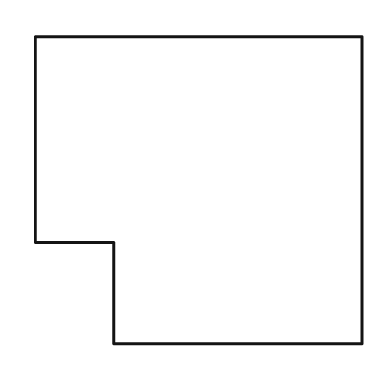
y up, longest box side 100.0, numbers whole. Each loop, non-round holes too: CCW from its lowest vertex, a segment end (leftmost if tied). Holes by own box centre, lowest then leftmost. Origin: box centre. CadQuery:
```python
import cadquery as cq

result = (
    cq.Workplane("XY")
    .moveTo(-26.0, -47.0)
    .lineTo(50.0, -47.0)
    .lineTo(50.0, 47.0)
    .lineTo(-50.0, 47.0)
    .lineTo(-50.0, -16.0)
    .lineTo(-26.0, -16.0)
    .close()
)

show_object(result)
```